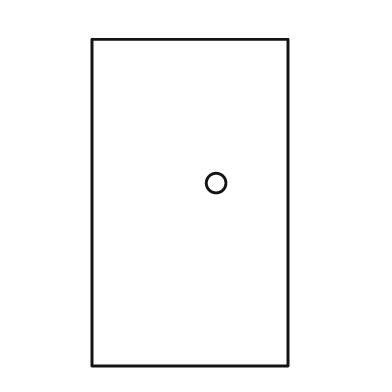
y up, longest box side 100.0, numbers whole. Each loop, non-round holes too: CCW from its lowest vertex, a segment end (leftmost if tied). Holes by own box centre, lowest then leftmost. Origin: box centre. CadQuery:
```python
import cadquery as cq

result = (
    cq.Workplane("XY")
    .moveTo(-30.0, -50.0)
    .lineTo(30.0, -50.0)
    .lineTo(30.0, 50.0)
    .lineTo(-30.0, 50.0)
    .close()
    .moveTo(8.0, 6.0)
    .circle(3.0)
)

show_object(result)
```